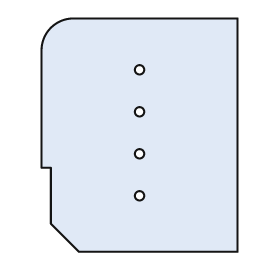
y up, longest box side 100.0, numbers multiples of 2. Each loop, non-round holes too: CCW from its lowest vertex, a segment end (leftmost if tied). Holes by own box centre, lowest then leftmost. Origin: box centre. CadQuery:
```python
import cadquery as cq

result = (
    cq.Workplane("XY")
    .moveTo(-26.0, -50.0)
    .lineTo(42.0, -50.0)
    .lineTo(42.0, 50.0)
    .lineTo(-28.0, 50.0)
    .threePointArc((-38.0, 46.0), (-42.0, 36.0))
    .lineTo(-42.0, -14.0)
    .lineTo(-38.0, -14.0)
    .lineTo(-38.0, -38.0)
    .close()
    .moveTo(0.0, -26.0)
    .circle(2.0)
    .moveTo(0.0, -8.0)
    .circle(2.0)
    .moveTo(0.0, 10.0)
    .circle(2.0)
    .moveTo(0.0, 28.0)
    .circle(2.0)
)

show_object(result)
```